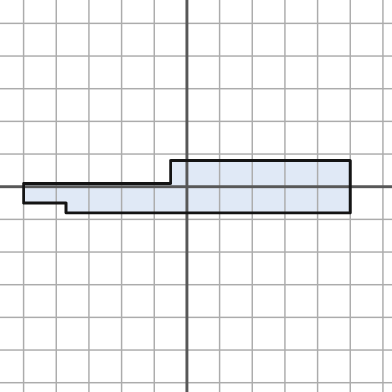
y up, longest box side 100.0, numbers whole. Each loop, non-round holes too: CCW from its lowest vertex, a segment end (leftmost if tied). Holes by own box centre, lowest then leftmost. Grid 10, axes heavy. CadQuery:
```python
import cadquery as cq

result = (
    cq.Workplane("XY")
    .moveTo(-37.0, -8.0)
    .lineTo(50.0, -8.0)
    .lineTo(50.0, 8.0)
    .lineTo(-5.0, 8.0)
    .lineTo(-5.0, 1.0)
    .lineTo(-50.0, 1.0)
    .lineTo(-50.0, -5.0)
    .lineTo(-37.0, -5.0)
    .close()
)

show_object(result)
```